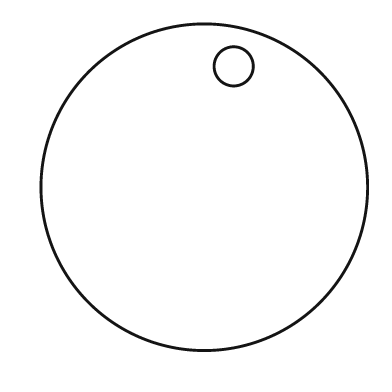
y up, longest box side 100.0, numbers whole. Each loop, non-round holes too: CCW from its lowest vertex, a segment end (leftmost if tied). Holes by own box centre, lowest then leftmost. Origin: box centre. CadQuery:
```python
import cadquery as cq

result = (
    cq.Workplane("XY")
    .moveTo(0.0, 0.0)
    .circle(50.0)
    .moveTo(9.0, 37.0)
    .circle(6.0)
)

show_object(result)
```